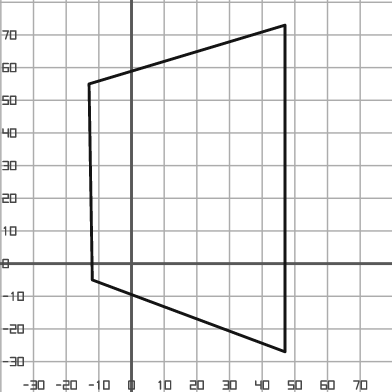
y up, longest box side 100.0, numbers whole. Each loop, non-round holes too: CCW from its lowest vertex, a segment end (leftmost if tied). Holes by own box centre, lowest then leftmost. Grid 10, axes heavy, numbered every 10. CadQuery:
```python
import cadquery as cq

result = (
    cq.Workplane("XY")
    .moveTo(47.0, -27.0)
    .lineTo(47.0, 73.0)
    .lineTo(-13.0, 55.0)
    .lineTo(-12.0, -5.0)
    .close()
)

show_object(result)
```